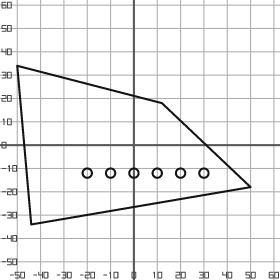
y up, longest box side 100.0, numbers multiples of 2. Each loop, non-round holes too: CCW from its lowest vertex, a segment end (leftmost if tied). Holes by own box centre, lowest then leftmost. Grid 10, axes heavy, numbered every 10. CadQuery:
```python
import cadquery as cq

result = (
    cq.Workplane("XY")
    .moveTo(-44.0, -34.0)
    .lineTo(50.0, -18.0)
    .lineTo(12.0, 18.0)
    .lineTo(-50.0, 34.0)
    .close()
    .moveTo(-20.0, -12.0)
    .circle(2.0)
    .moveTo(-10.0, -12.0)
    .circle(2.0)
    .moveTo(0.0, -12.0)
    .circle(2.0)
    .moveTo(10.0, -12.0)
    .circle(2.0)
    .moveTo(20.0, -12.0)
    .circle(2.0)
    .moveTo(30.0, -12.0)
    .circle(2.0)
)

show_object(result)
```